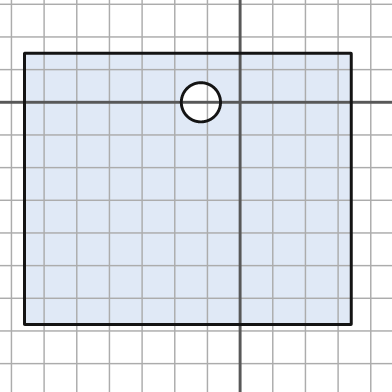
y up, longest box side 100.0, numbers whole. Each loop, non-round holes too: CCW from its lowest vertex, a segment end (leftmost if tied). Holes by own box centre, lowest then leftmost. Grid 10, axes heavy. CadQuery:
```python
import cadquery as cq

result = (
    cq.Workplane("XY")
    .moveTo(-66.0, -68.0)
    .lineTo(34.0, -68.0)
    .lineTo(34.0, 15.0)
    .lineTo(-66.0, 15.0)
    .close()
    .moveTo(-12.0, 0.0)
    .circle(6.0)
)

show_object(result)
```